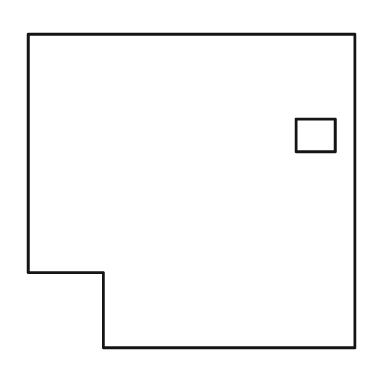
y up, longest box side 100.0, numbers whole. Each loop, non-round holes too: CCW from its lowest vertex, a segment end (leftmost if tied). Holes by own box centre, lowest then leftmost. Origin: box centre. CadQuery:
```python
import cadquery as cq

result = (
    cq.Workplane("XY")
    .moveTo(-27.0, -48.0)
    .lineTo(50.0, -48.0)
    .lineTo(50.0, 48.0)
    .lineTo(-50.0, 48.0)
    .lineTo(-50.0, -25.0)
    .lineTo(-27.0, -25.0)
    .close()
    .moveTo(32.0, 12.0)
    .lineTo(44.0, 12.0)
    .lineTo(44.0, 22.0)
    .lineTo(32.0, 22.0)
    .close()
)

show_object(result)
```